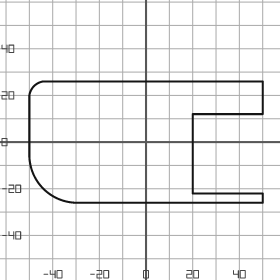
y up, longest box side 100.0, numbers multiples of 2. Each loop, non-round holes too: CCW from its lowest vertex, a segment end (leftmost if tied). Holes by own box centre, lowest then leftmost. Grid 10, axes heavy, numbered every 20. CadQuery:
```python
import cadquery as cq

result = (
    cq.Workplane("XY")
    .moveTo(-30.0, -26.0)
    .lineTo(50.0, -26.0)
    .lineTo(50.0, -22.0)
    .lineTo(20.0, -22.0)
    .lineTo(20.0, 12.0)
    .lineTo(50.0, 12.0)
    .lineTo(50.0, 26.0)
    .lineTo(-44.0, 26.0)
    .threePointArc((-48.0, 24.0), (-50.0, 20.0))
    .lineTo(-50.0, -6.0)
    .threePointArc((-44.0, -20.0), (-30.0, -26.0))
    .close()
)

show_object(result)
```